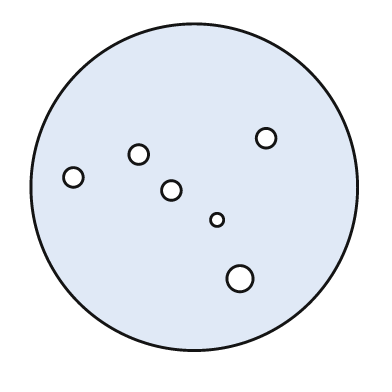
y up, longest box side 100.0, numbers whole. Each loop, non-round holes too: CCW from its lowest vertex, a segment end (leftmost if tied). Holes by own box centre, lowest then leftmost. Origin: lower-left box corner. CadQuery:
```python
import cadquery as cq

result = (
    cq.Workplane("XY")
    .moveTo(50.0, 50.0)
    .circle(50.0)
    .moveTo(64.0, 22.0)
    .circle(4.0)
    .moveTo(57.0, 40.0)
    .circle(2.0)
    .moveTo(43.0, 49.0)
    .circle(3.0)
    .moveTo(13.0, 53.0)
    .circle(3.0)
    .moveTo(33.0, 60.0)
    .circle(3.0)
    .moveTo(72.0, 65.0)
    .circle(3.0)
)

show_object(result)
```